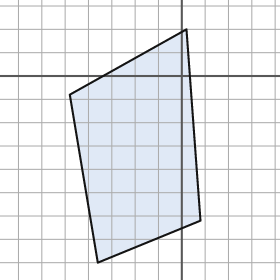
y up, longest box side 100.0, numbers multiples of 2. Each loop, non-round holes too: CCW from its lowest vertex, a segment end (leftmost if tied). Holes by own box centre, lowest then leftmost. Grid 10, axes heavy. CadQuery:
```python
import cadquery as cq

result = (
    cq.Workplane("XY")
    .moveTo(-36.0, -80.0)
    .lineTo(8.0, -62.0)
    .lineTo(2.0, 20.0)
    .lineTo(-48.0, -8.0)
    .close()
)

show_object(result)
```